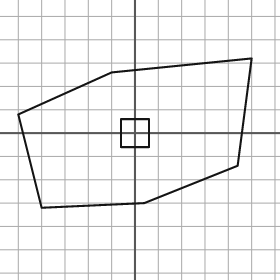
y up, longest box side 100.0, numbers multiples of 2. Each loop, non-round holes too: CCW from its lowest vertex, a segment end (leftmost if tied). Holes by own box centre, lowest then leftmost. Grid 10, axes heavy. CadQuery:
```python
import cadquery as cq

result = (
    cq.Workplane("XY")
    .moveTo(-40.0, -32.0)
    .lineTo(4.0, -30.0)
    .lineTo(44.0, -14.0)
    .lineTo(50.0, 32.0)
    .lineTo(-10.0, 26.0)
    .lineTo(-50.0, 8.0)
    .close()
    .moveTo(-6.0, -6.0)
    .lineTo(6.0, -6.0)
    .lineTo(6.0, 6.0)
    .lineTo(-6.0, 6.0)
    .close()
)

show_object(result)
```